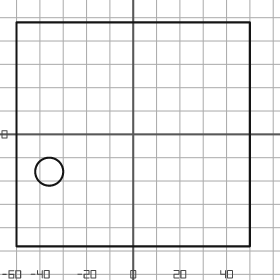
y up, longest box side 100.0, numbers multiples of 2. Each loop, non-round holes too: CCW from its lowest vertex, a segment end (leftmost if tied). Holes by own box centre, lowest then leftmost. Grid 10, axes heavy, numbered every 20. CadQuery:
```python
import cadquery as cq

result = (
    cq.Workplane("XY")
    .moveTo(-50.0, -48.0)
    .lineTo(50.0, -48.0)
    .lineTo(50.0, 48.0)
    .lineTo(-50.0, 48.0)
    .close()
    .moveTo(-36.0, -16.0)
    .circle(6.0)
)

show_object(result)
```